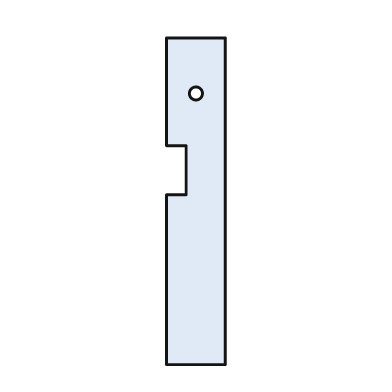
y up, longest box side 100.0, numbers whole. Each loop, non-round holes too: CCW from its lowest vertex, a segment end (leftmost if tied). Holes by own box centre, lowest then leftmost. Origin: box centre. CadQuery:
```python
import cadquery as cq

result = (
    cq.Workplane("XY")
    .moveTo(-9.0, -50.0)
    .lineTo(9.0, -50.0)
    .lineTo(9.0, 50.0)
    .lineTo(-9.0, 50.0)
    .lineTo(-9.0, 17.0)
    .lineTo(-3.0, 17.0)
    .lineTo(-3.0, 2.0)
    .lineTo(-9.0, 2.0)
    .close()
    .moveTo(0.0, 33.0)
    .circle(2.0)
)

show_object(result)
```